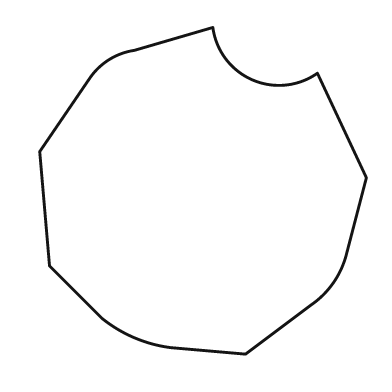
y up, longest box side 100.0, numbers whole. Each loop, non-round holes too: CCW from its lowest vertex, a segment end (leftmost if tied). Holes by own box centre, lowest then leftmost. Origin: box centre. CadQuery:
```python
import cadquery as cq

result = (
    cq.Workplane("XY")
    .moveTo(13.0, -50.0)
    .lineTo(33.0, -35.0)
    .threePointArc((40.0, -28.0), (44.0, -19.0))
    .lineTo(50.0, 4.0)
    .lineTo(35.0, 36.0)
    .threePointArc((15.0, 34.0), (3.0, 50.0))
    .lineTo(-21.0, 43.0)
    .threePointArc((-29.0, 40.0), (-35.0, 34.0))
    .lineTo(-50.0, 12.0)
    .lineTo(-47.0, -23.0)
    .lineTo(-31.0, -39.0)
    .threePointArc((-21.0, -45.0), (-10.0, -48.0))
    .close()
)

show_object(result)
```